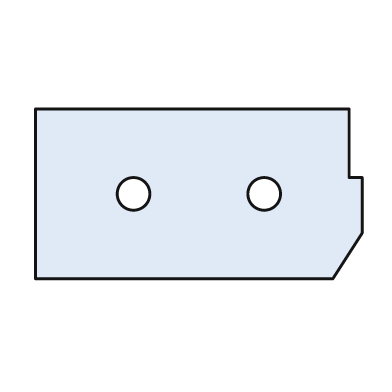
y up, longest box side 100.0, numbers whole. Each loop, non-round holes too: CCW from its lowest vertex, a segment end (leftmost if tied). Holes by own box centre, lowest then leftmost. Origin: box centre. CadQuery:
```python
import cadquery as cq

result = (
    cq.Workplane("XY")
    .moveTo(-50.0, -26.0)
    .lineTo(41.0, -26.0)
    .lineTo(50.0, -12.0)
    .lineTo(50.0, 5.0)
    .lineTo(46.0, 5.0)
    .lineTo(46.0, 26.0)
    .lineTo(-50.0, 26.0)
    .close()
    .moveTo(-20.0, 0.0)
    .circle(5.0)
    .moveTo(20.0, 0.0)
    .circle(5.0)
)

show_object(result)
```